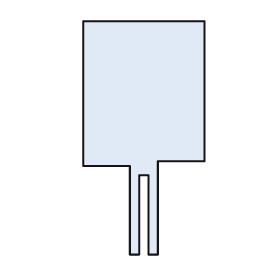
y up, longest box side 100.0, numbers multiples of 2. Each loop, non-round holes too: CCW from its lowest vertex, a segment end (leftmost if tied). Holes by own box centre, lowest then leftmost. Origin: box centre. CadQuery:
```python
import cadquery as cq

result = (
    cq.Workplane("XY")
    .moveTo(-6.0, -50.0)
    .lineTo(-2.0, -50.0)
    .lineTo(-2.0, -16.0)
    .lineTo(2.0, -16.0)
    .lineTo(2.0, -50.0)
    .lineTo(6.0, -50.0)
    .lineTo(6.0, -10.0)
    .lineTo(26.0, -10.0)
    .lineTo(26.0, 50.0)
    .lineTo(-26.0, 50.0)
    .lineTo(-26.0, -12.0)
    .lineTo(-6.0, -12.0)
    .close()
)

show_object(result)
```